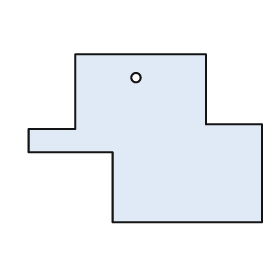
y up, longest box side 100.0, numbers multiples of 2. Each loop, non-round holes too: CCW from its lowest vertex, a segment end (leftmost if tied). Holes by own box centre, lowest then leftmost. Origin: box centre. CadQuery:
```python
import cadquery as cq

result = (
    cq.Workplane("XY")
    .moveTo(-14.0, -36.0)
    .lineTo(50.0, -36.0)
    .lineTo(50.0, 6.0)
    .lineTo(26.0, 6.0)
    .lineTo(26.0, 36.0)
    .lineTo(-30.0, 36.0)
    .lineTo(-30.0, 4.0)
    .lineTo(-50.0, 4.0)
    .lineTo(-50.0, -6.0)
    .lineTo(-14.0, -6.0)
    .close()
    .moveTo(-4.0, 26.0)
    .circle(2.0)
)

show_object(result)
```